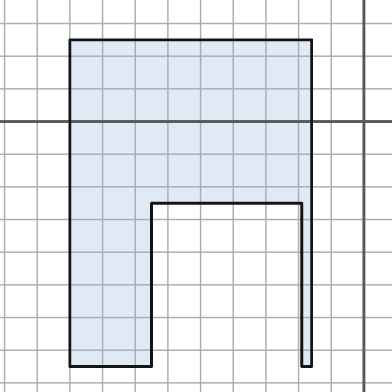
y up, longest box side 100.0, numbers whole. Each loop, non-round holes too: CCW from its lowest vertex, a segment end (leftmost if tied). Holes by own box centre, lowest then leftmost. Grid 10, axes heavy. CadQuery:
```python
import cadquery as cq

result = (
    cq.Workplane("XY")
    .moveTo(-90.0, -75.0)
    .lineTo(-65.0, -75.0)
    .lineTo(-65.0, -25.0)
    .lineTo(-19.0, -25.0)
    .lineTo(-19.0, -75.0)
    .lineTo(-16.0, -75.0)
    .lineTo(-16.0, 25.0)
    .lineTo(-90.0, 25.0)
    .close()
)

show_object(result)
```